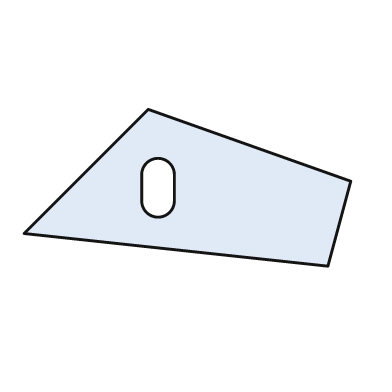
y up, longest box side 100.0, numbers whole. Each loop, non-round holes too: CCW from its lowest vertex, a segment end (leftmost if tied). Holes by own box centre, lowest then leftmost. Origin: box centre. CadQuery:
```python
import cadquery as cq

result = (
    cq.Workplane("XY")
    .moveTo(43.0, -24.0)
    .lineTo(50.0, 2.0)
    .lineTo(-12.0, 24.0)
    .lineTo(-50.0, -14.0)
    .close()
    .moveTo(-14.0, -4.0)
    .threePointArc((-9.0, -9.0), (-4.0, -4.0))
    .lineTo(-4.0, 4.0)
    .threePointArc((-9.0, 9.0), (-14.0, 4.0))
    .close()
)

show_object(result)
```